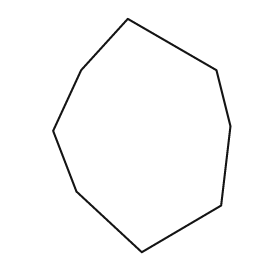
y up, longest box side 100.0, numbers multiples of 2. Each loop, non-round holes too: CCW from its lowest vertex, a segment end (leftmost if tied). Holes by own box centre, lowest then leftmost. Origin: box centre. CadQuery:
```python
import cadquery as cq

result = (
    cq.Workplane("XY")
    .moveTo(0.0, -50.0)
    .lineTo(34.0, -30.0)
    .lineTo(38.0, 4.0)
    .lineTo(32.0, 28.0)
    .lineTo(-6.0, 50.0)
    .lineTo(-26.0, 28.0)
    .lineTo(-38.0, 2.0)
    .lineTo(-28.0, -24.0)
    .close()
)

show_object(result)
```